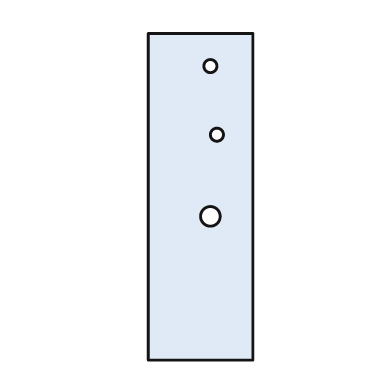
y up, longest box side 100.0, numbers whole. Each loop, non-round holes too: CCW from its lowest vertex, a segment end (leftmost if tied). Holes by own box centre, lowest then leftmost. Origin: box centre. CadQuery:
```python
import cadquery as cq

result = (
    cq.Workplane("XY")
    .moveTo(-16.0, -50.0)
    .lineTo(16.0, -50.0)
    .lineTo(16.0, 50.0)
    .lineTo(-16.0, 50.0)
    .close()
    .moveTo(3.0, -6.0)
    .circle(3.0)
    .moveTo(5.0, 19.0)
    .circle(2.0)
    .moveTo(3.0, 40.0)
    .circle(2.0)
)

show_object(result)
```